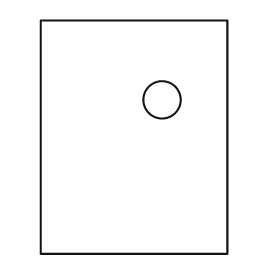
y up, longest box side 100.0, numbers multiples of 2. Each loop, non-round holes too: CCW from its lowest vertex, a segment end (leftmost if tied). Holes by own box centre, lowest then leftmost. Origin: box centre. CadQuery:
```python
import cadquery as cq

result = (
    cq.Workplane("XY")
    .moveTo(-40.0, -50.0)
    .lineTo(40.0, -50.0)
    .lineTo(40.0, 50.0)
    .lineTo(-40.0, 50.0)
    .close()
    .moveTo(12.0, 16.0)
    .circle(8.0)
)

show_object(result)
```